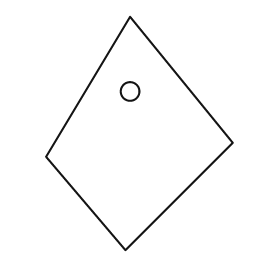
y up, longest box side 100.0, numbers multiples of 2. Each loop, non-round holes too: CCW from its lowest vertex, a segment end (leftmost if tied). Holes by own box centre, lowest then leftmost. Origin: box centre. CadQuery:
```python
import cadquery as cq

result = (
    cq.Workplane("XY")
    .moveTo(-6.0, -50.0)
    .lineTo(40.0, -4.0)
    .lineTo(-4.0, 50.0)
    .lineTo(-40.0, -10.0)
    .close()
    .moveTo(-4.0, 18.0)
    .circle(4.0)
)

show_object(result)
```